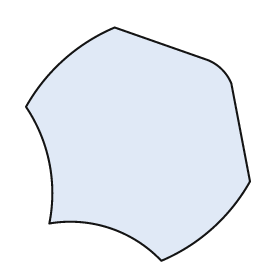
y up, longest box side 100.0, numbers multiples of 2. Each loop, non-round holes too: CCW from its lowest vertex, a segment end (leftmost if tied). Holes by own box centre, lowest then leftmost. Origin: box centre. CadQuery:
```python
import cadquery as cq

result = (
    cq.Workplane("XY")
    .moveTo(10.0, -50.0)
    .threePointArc((32.0, -36.0), (48.0, -16.0))
    .lineTo(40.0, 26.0)
    .threePointArc((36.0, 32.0), (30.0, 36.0))
    .lineTo(-10.0, 50.0)
    .threePointArc((-32.0, 36.0), (-48.0, 16.0))
    .threePointArc((-38.0, -8.0), (-38.0, -34.0))
    .threePointArc((-12.0, -36.0), (10.0, -50.0))
    .close()
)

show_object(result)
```